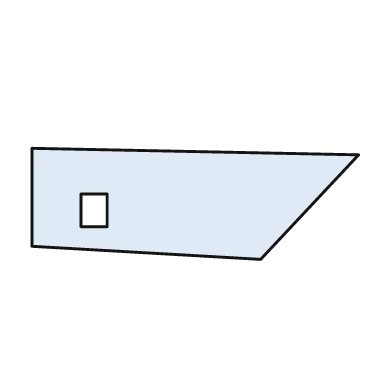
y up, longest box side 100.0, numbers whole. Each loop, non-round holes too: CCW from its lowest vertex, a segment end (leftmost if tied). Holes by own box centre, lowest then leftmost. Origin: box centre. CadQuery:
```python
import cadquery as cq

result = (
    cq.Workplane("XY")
    .moveTo(20.0, -17.0)
    .lineTo(50.0, 15.0)
    .lineTo(-50.0, 17.0)
    .lineTo(-50.0, -13.0)
    .close()
    .moveTo(-35.0, -7.0)
    .lineTo(-27.0, -7.0)
    .lineTo(-27.0, 3.0)
    .lineTo(-35.0, 3.0)
    .close()
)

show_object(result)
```